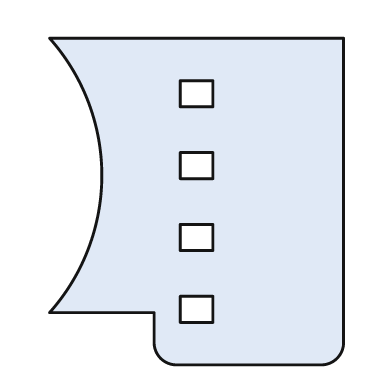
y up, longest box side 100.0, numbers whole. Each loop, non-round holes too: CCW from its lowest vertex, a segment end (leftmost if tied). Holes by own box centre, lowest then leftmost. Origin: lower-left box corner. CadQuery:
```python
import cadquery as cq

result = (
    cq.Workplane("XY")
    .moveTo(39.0, 0.0)
    .lineTo(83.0, 0.0)
    .threePointArc((88.0, 2.0), (90.0, 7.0))
    .lineTo(90.0, 100.0)
    .lineTo(0.0, 100.0)
    .threePointArc((16.0, 58.0), (0.0, 16.0))
    .lineTo(32.0, 16.0)
    .lineTo(32.0, 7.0)
    .threePointArc((34.0, 2.0), (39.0, 0.0))
    .close()
    .moveTo(40.0, 13.0)
    .lineTo(50.0, 13.0)
    .lineTo(50.0, 21.0)
    .lineTo(40.0, 21.0)
    .close()
    .moveTo(40.0, 35.0)
    .lineTo(50.0, 35.0)
    .lineTo(50.0, 43.0)
    .lineTo(40.0, 43.0)
    .close()
    .moveTo(40.0, 57.0)
    .lineTo(50.0, 57.0)
    .lineTo(50.0, 65.0)
    .lineTo(40.0, 65.0)
    .close()
    .moveTo(40.0, 79.0)
    .lineTo(50.0, 79.0)
    .lineTo(50.0, 87.0)
    .lineTo(40.0, 87.0)
    .close()
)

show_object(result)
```